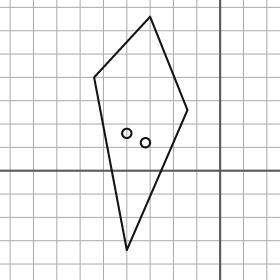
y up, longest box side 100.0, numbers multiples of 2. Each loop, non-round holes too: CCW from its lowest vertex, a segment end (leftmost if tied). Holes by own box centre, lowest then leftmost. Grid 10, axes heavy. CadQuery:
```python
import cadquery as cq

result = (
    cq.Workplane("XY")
    .moveTo(-40.0, -34.0)
    .lineTo(-14.0, 26.0)
    .lineTo(-30.0, 66.0)
    .lineTo(-54.0, 40.0)
    .close()
    .moveTo(-32.0, 12.0)
    .circle(2.0)
    .moveTo(-40.0, 16.0)
    .circle(2.0)
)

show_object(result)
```